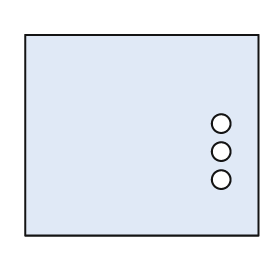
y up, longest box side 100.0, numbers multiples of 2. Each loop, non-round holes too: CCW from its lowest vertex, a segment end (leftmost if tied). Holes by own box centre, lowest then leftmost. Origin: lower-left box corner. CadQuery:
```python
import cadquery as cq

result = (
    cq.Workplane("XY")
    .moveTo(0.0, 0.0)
    .lineTo(100.0, 0.0)
    .lineTo(100.0, 86.0)
    .lineTo(0.0, 86.0)
    .close()
    .moveTo(84.0, 24.0)
    .circle(4.0)
    .moveTo(84.0, 36.0)
    .circle(4.0)
    .moveTo(84.0, 48.0)
    .circle(4.0)
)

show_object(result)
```